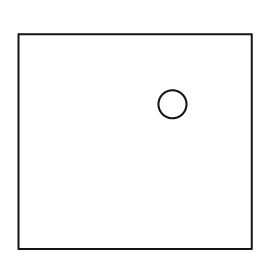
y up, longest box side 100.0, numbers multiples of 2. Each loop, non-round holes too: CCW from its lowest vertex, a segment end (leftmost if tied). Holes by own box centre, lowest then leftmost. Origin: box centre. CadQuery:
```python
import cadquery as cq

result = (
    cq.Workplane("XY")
    .moveTo(-50.0, -46.0)
    .lineTo(50.0, -46.0)
    .lineTo(50.0, 46.0)
    .lineTo(-50.0, 46.0)
    .close()
    .moveTo(16.0, 16.0)
    .circle(6.0)
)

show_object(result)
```